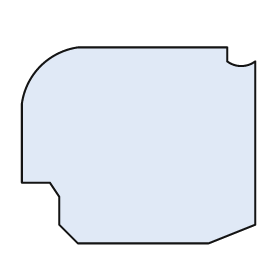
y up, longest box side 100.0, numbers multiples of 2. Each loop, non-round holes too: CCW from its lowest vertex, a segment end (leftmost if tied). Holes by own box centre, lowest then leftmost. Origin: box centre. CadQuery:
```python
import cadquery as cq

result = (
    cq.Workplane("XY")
    .moveTo(-26.0, -42.0)
    .lineTo(30.0, -42.0)
    .lineTo(50.0, -34.0)
    .lineTo(50.0, 36.0)
    .threePointArc((44.0, 34.0), (38.0, 36.0))
    .lineTo(38.0, 42.0)
    .lineTo(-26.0, 42.0)
    .threePointArc((-42.0, 34.0), (-50.0, 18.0))
    .lineTo(-50.0, -16.0)
    .lineTo(-38.0, -16.0)
    .lineTo(-34.0, -22.0)
    .lineTo(-34.0, -34.0)
    .close()
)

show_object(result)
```